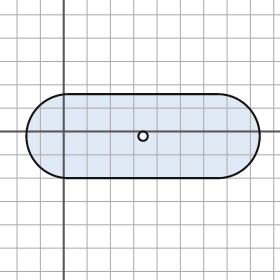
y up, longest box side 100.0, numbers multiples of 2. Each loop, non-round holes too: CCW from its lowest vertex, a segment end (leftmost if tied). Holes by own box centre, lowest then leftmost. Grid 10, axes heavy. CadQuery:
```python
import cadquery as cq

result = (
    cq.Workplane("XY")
    .moveTo(2.0, -20.0)
    .lineTo(66.0, -20.0)
    .threePointArc((84.0, -2.0), (66.0, 16.0))
    .lineTo(2.0, 16.0)
    .threePointArc((-16.0, -2.0), (2.0, -20.0))
    .close()
    .moveTo(34.0, -2.0)
    .circle(2.0)
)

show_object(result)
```